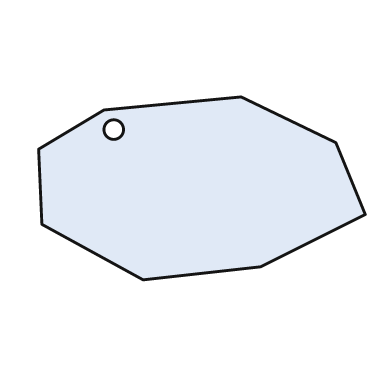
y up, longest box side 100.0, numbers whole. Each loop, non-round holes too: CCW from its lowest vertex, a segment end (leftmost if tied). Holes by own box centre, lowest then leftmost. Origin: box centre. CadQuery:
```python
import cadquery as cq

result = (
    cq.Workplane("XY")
    .moveTo(-18.0, -28.0)
    .lineTo(18.0, -24.0)
    .lineTo(50.0, -8.0)
    .lineTo(41.0, 14.0)
    .lineTo(12.0, 28.0)
    .lineTo(-30.0, 24.0)
    .lineTo(-50.0, 12.0)
    .lineTo(-49.0, -11.0)
    .close()
    .moveTo(-27.0, 18.0)
    .circle(3.0)
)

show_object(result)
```